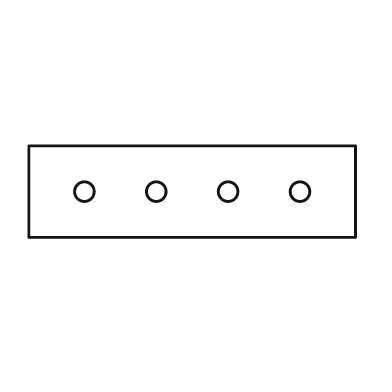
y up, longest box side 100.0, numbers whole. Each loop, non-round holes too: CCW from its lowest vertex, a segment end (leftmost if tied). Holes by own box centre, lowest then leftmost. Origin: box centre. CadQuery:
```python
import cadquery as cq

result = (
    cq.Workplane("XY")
    .moveTo(-50.0, -14.0)
    .lineTo(50.0, -14.0)
    .lineTo(50.0, 14.0)
    .lineTo(-50.0, 14.0)
    .close()
    .moveTo(-33.0, 0.0)
    .circle(3.0)
    .moveTo(-11.0, 0.0)
    .circle(3.0)
    .moveTo(11.0, 0.0)
    .circle(3.0)
    .moveTo(33.0, 0.0)
    .circle(3.0)
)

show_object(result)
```